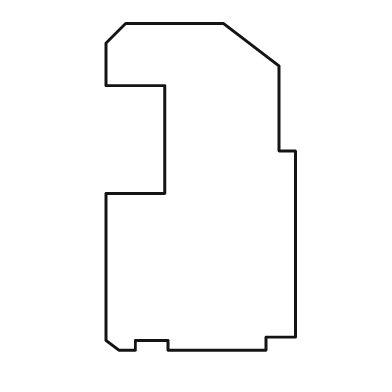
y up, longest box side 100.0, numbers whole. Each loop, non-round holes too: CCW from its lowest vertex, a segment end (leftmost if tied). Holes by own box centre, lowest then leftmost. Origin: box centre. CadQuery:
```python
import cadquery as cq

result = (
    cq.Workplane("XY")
    .moveTo(-25.0, -50.0)
    .lineTo(-20.0, -50.0)
    .lineTo(-20.0, -47.0)
    .lineTo(-10.0, -47.0)
    .lineTo(-10.0, -50.0)
    .lineTo(20.0, -50.0)
    .lineTo(20.0, -46.0)
    .lineTo(29.0, -46.0)
    .lineTo(29.0, 11.0)
    .lineTo(24.0, 11.0)
    .lineTo(24.0, 37.0)
    .lineTo(7.0, 50.0)
    .lineTo(-23.0, 50.0)
    .lineTo(-29.0, 44.0)
    .lineTo(-29.0, 31.0)
    .lineTo(-11.0, 31.0)
    .lineTo(-11.0, -2.0)
    .lineTo(-29.0, -2.0)
    .lineTo(-29.0, -47.0)
    .close()
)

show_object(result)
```